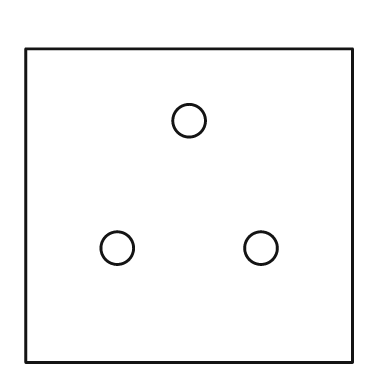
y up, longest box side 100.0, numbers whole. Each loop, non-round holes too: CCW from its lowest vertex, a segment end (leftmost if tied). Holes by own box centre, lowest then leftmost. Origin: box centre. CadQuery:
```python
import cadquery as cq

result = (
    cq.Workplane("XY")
    .moveTo(-50.0, -48.0)
    .lineTo(50.0, -48.0)
    .lineTo(50.0, 48.0)
    .lineTo(-50.0, 48.0)
    .close()
    .moveTo(-22.0, -13.0)
    .circle(5.0)
    .moveTo(22.0, -13.0)
    .circle(5.0)
    .moveTo(0.0, 26.0)
    .circle(5.0)
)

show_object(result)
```